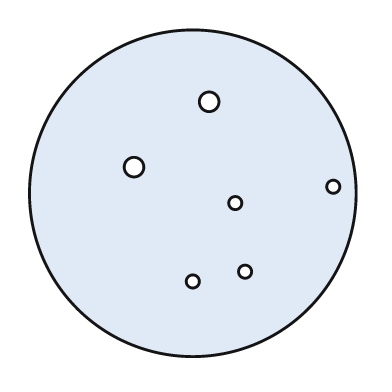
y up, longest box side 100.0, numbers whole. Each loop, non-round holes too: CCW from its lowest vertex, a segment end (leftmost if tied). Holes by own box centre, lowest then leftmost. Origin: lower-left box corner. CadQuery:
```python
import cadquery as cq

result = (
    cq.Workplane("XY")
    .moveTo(50.0, 50.0)
    .circle(50.0)
    .moveTo(50.0, 23.0)
    .circle(2.0)
    .moveTo(66.0, 26.0)
    .circle(2.0)
    .moveTo(63.0, 47.0)
    .circle(2.0)
    .moveTo(93.0, 52.0)
    .circle(2.0)
    .moveTo(32.0, 58.0)
    .circle(3.0)
    .moveTo(55.0, 78.0)
    .circle(3.0)
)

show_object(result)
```